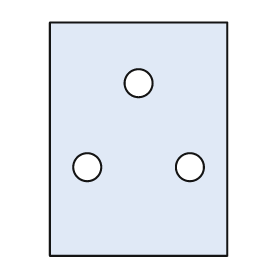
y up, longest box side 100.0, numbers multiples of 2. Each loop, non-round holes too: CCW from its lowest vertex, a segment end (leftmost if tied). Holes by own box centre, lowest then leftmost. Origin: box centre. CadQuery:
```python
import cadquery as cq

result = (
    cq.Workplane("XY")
    .moveTo(-38.0, -50.0)
    .lineTo(38.0, -50.0)
    .lineTo(38.0, 50.0)
    .lineTo(-38.0, 50.0)
    .close()
    .moveTo(-22.0, -12.0)
    .circle(6.0)
    .moveTo(22.0, -12.0)
    .circle(6.0)
    .moveTo(0.0, 24.0)
    .circle(6.0)
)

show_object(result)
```